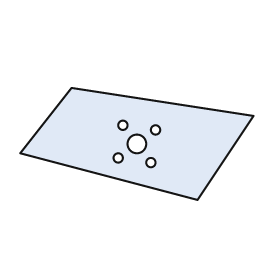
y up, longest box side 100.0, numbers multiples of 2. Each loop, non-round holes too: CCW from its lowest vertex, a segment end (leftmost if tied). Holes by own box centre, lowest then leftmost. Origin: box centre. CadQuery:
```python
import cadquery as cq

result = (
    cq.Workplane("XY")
    .moveTo(26.0, -24.0)
    .lineTo(50.0, 12.0)
    .lineTo(-28.0, 24.0)
    .lineTo(-50.0, -4.0)
    .close()
    .moveTo(6.0, -8.0)
    .circle(2.0)
    .moveTo(-8.0, -6.0)
    .circle(2.0)
    .moveTo(0.0, 0.0)
    .circle(4.0)
    .moveTo(8.0, 6.0)
    .circle(2.0)
    .moveTo(-6.0, 8.0)
    .circle(2.0)
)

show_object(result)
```